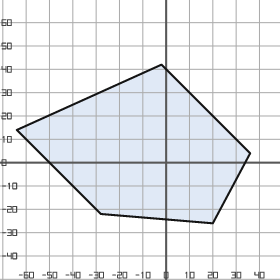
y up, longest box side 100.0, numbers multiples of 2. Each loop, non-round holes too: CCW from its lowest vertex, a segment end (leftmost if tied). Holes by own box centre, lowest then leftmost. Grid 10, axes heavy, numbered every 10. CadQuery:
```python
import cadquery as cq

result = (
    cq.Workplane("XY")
    .moveTo(20.0, -26.0)
    .lineTo(36.0, 4.0)
    .lineTo(-2.0, 42.0)
    .lineTo(-64.0, 14.0)
    .lineTo(-28.0, -22.0)
    .close()
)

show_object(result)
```